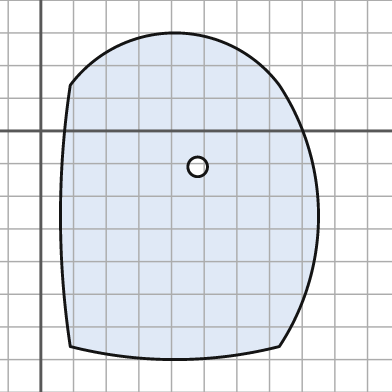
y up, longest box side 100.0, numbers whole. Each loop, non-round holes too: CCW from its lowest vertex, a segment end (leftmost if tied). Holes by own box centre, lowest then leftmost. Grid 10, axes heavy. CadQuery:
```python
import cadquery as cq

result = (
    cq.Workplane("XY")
    .moveTo(9.0, -66.0)
    .threePointArc((41.0, -70.0), (73.0, -66.0))
    .threePointArc((85.0, -26.0), (73.0, 14.0))
    .threePointArc((41.0, 30.0), (9.0, 14.0))
    .threePointArc((6.0, -26.0), (9.0, -66.0))
    .close()
    .moveTo(48.0, -11.0)
    .circle(3.0)
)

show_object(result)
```